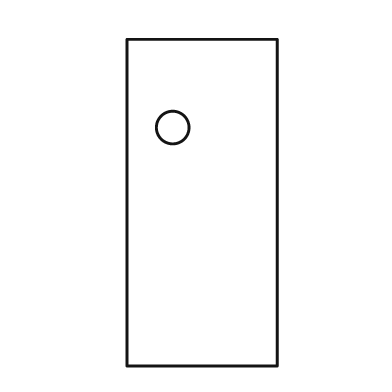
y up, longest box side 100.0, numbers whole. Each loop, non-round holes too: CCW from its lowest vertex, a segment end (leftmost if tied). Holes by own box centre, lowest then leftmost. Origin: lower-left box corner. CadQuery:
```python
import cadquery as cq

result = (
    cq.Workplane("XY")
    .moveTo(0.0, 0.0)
    .lineTo(46.0, 0.0)
    .lineTo(46.0, 100.0)
    .lineTo(0.0, 100.0)
    .close()
    .moveTo(14.0, 73.0)
    .circle(5.0)
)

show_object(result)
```